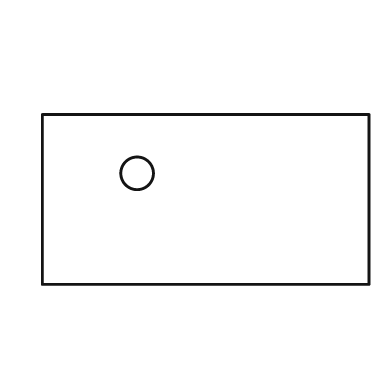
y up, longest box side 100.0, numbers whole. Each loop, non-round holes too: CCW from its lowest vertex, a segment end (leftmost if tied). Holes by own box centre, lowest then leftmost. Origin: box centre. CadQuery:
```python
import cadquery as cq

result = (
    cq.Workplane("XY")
    .moveTo(-50.0, -26.0)
    .lineTo(50.0, -26.0)
    .lineTo(50.0, 26.0)
    .lineTo(-50.0, 26.0)
    .close()
    .moveTo(-21.0, 8.0)
    .circle(5.0)
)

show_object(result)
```